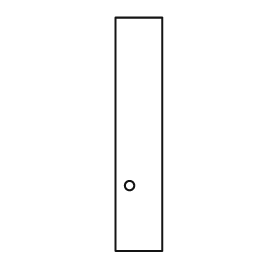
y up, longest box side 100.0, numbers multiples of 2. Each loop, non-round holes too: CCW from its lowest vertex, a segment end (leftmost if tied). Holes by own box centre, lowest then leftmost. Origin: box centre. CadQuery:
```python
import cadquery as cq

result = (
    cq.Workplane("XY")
    .moveTo(-10.0, -50.0)
    .lineTo(10.0, -50.0)
    .lineTo(10.0, 50.0)
    .lineTo(-10.0, 50.0)
    .close()
    .moveTo(-4.0, -22.0)
    .circle(2.0)
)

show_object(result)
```